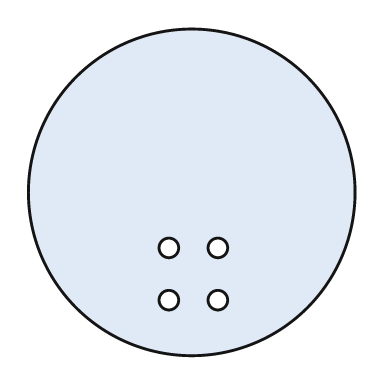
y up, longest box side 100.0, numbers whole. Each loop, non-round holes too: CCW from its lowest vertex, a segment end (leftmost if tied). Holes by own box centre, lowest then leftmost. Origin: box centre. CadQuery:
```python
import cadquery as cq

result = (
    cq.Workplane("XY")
    .moveTo(0.0, 0.0)
    .circle(50.0)
    .moveTo(-7.0, -33.0)
    .circle(3.0)
    .moveTo(8.0, -33.0)
    .circle(3.0)
    .moveTo(-7.0, -17.0)
    .circle(3.0)
    .moveTo(8.0, -17.0)
    .circle(3.0)
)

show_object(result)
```